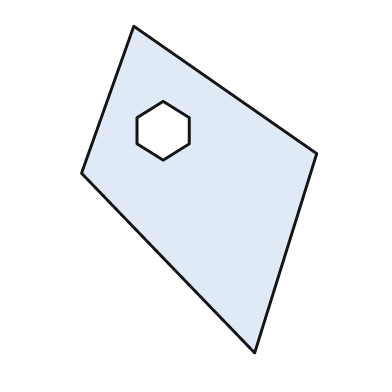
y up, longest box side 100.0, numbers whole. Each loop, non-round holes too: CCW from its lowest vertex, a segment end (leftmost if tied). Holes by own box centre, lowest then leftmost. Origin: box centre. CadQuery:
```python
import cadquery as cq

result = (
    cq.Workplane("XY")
    .moveTo(17.0, -50.0)
    .lineTo(36.0, 11.0)
    .lineTo(-20.0, 50.0)
    .lineTo(-36.0, 5.0)
    .close()
    .moveTo(-11.0, 9.0)
    .lineTo(-3.0, 14.0)
    .lineTo(-3.0, 22.0)
    .lineTo(-11.0, 27.0)
    .lineTo(-19.0, 22.0)
    .lineTo(-19.0, 14.0)
    .close()
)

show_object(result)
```